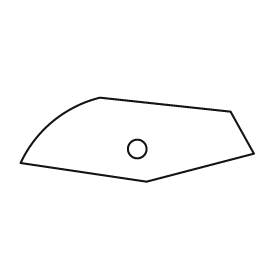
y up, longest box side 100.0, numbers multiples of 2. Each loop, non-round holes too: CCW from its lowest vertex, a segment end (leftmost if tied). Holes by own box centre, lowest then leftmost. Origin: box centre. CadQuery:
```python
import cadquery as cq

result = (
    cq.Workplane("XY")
    .moveTo(4.0, -18.0)
    .lineTo(50.0, -6.0)
    .lineTo(40.0, 12.0)
    .lineTo(-16.0, 18.0)
    .threePointArc((-36.0, 8.0), (-50.0, -10.0))
    .close()
    .moveTo(0.0, -4.0)
    .circle(4.0)
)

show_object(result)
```